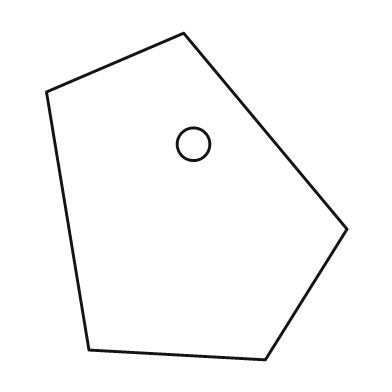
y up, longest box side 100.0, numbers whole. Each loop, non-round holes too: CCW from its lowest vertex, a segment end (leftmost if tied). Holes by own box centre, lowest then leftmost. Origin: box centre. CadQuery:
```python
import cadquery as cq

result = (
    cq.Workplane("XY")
    .moveTo(21.0, -50.0)
    .lineTo(46.0, -10.0)
    .lineTo(-4.0, 50.0)
    .lineTo(-46.0, 32.0)
    .lineTo(-33.0, -47.0)
    .close()
    .moveTo(-1.0, 16.0)
    .circle(5.0)
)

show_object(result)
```